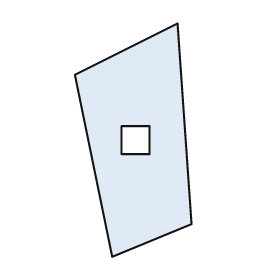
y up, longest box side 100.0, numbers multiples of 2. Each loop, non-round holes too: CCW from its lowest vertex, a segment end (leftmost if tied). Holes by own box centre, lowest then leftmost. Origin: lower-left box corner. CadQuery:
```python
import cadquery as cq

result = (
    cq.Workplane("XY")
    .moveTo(16.0, 0.0)
    .lineTo(50.0, 14.0)
    .lineTo(44.0, 100.0)
    .lineTo(0.0, 78.0)
    .close()
    .moveTo(20.0, 44.0)
    .lineTo(32.0, 44.0)
    .lineTo(32.0, 56.0)
    .lineTo(20.0, 56.0)
    .close()
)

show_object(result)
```